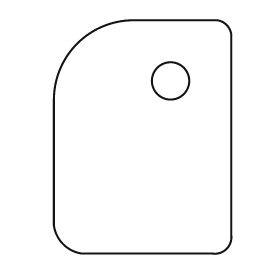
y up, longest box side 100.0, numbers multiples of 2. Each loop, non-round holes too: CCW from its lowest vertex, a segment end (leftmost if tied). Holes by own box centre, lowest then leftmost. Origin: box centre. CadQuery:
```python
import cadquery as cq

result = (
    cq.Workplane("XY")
    .moveTo(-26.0, -50.0)
    .lineTo(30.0, -50.0)
    .threePointArc((36.0, -48.0), (38.0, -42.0))
    .lineTo(38.0, 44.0)
    .threePointArc((36.0, 48.0), (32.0, 50.0))
    .lineTo(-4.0, 50.0)
    .threePointArc((-28.0, 40.0), (-38.0, 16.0))
    .lineTo(-38.0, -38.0)
    .threePointArc((-34.0, -46.0), (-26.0, -50.0))
    .close()
    .moveTo(12.0, 24.0)
    .circle(8.0)
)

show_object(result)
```